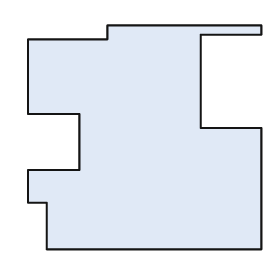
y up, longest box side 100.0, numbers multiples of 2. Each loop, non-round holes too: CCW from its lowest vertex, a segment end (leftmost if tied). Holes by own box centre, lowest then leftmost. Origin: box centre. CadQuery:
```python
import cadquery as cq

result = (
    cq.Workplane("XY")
    .moveTo(-42.0, -48.0)
    .lineTo(50.0, -48.0)
    .lineTo(50.0, 4.0)
    .lineTo(24.0, 4.0)
    .lineTo(24.0, 44.0)
    .lineTo(50.0, 44.0)
    .lineTo(50.0, 48.0)
    .lineTo(-16.0, 48.0)
    .lineTo(-16.0, 42.0)
    .lineTo(-50.0, 42.0)
    .lineTo(-50.0, 10.0)
    .lineTo(-28.0, 10.0)
    .lineTo(-28.0, -14.0)
    .lineTo(-50.0, -14.0)
    .lineTo(-50.0, -28.0)
    .lineTo(-42.0, -28.0)
    .close()
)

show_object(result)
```